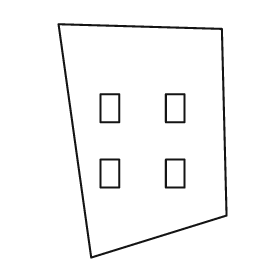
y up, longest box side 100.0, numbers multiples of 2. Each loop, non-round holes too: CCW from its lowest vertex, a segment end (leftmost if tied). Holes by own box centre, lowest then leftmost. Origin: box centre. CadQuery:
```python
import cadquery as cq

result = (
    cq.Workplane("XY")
    .moveTo(-22.0, -50.0)
    .lineTo(36.0, -32.0)
    .lineTo(34.0, 48.0)
    .lineTo(-36.0, 50.0)
    .close()
    .moveTo(-18.0, -20.0)
    .lineTo(-10.0, -20.0)
    .lineTo(-10.0, -8.0)
    .lineTo(-18.0, -8.0)
    .close()
    .moveTo(10.0, -20.0)
    .lineTo(18.0, -20.0)
    .lineTo(18.0, -8.0)
    .lineTo(10.0, -8.0)
    .close()
    .moveTo(-18.0, 8.0)
    .lineTo(-10.0, 8.0)
    .lineTo(-10.0, 20.0)
    .lineTo(-18.0, 20.0)
    .close()
    .moveTo(10.0, 8.0)
    .lineTo(18.0, 8.0)
    .lineTo(18.0, 20.0)
    .lineTo(10.0, 20.0)
    .close()
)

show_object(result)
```